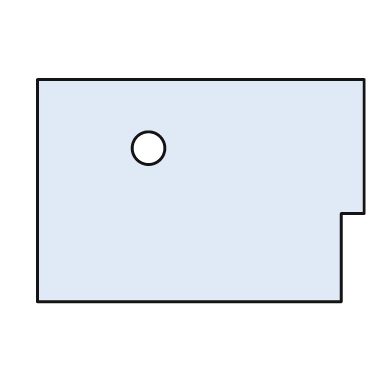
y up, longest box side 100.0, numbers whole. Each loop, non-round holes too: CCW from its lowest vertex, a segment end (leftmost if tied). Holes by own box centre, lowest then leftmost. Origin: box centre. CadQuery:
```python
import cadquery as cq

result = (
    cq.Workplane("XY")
    .moveTo(-50.0, -34.0)
    .lineTo(43.0, -34.0)
    .lineTo(43.0, -7.0)
    .lineTo(50.0, -7.0)
    .lineTo(50.0, 34.0)
    .lineTo(-50.0, 34.0)
    .close()
    .moveTo(-16.0, 13.0)
    .circle(5.0)
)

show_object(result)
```